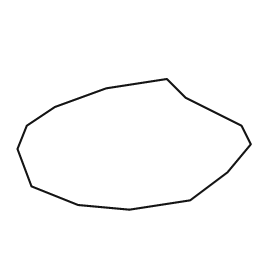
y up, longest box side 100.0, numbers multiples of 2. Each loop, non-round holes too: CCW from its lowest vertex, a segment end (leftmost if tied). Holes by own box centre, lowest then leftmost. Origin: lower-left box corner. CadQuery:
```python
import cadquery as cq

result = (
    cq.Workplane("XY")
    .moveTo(48.0, 0.0)
    .lineTo(74.0, 4.0)
    .lineTo(90.0, 16.0)
    .lineTo(100.0, 28.0)
    .lineTo(96.0, 36.0)
    .lineTo(72.0, 48.0)
    .lineTo(64.0, 56.0)
    .lineTo(38.0, 52.0)
    .lineTo(16.0, 44.0)
    .lineTo(4.0, 36.0)
    .lineTo(0.0, 26.0)
    .lineTo(6.0, 10.0)
    .lineTo(26.0, 2.0)
    .close()
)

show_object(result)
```